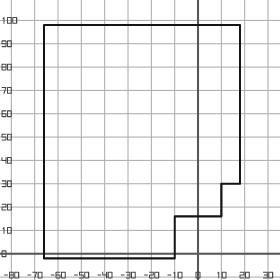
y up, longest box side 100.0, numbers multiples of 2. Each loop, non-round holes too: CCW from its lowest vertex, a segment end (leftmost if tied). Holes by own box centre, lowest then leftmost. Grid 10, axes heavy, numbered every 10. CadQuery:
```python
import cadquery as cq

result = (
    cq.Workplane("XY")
    .moveTo(-66.0, -2.0)
    .lineTo(-10.0, -2.0)
    .lineTo(-10.0, 16.0)
    .lineTo(10.0, 16.0)
    .lineTo(10.0, 30.0)
    .lineTo(18.0, 30.0)
    .lineTo(18.0, 98.0)
    .lineTo(-66.0, 98.0)
    .close()
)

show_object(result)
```